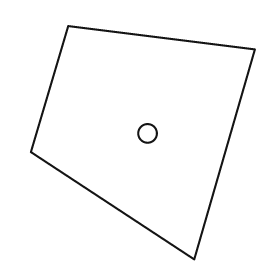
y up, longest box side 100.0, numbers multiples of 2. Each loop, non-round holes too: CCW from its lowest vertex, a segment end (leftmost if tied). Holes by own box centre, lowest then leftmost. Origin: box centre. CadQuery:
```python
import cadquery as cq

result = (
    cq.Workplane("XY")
    .moveTo(22.0, -50.0)
    .lineTo(48.0, 40.0)
    .lineTo(-32.0, 50.0)
    .lineTo(-48.0, -4.0)
    .close()
    .moveTo(2.0, 4.0)
    .circle(4.0)
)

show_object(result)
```